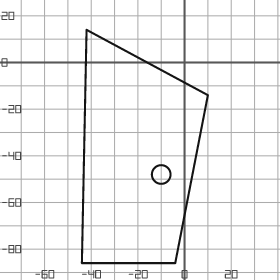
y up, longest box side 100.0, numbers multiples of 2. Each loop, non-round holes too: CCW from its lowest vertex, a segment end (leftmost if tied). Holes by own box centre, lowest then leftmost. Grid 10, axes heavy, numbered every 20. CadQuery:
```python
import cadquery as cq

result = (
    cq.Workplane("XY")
    .moveTo(-44.0, -86.0)
    .lineTo(-4.0, -86.0)
    .lineTo(10.0, -14.0)
    .lineTo(-42.0, 14.0)
    .close()
    .moveTo(-10.0, -48.0)
    .circle(4.0)
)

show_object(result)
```